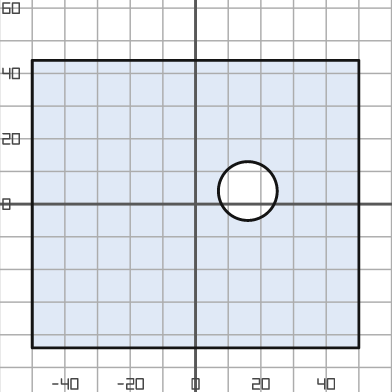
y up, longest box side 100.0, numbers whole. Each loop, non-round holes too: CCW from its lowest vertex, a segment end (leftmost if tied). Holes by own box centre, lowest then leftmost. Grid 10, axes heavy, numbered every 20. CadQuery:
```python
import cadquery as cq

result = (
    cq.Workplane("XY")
    .moveTo(-50.0, -44.0)
    .lineTo(50.0, -44.0)
    .lineTo(50.0, 44.0)
    .lineTo(-50.0, 44.0)
    .close()
    .moveTo(16.0, 4.0)
    .circle(9.0)
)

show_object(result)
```